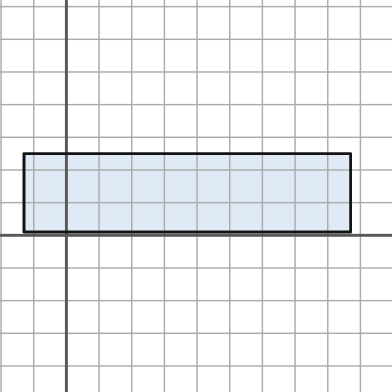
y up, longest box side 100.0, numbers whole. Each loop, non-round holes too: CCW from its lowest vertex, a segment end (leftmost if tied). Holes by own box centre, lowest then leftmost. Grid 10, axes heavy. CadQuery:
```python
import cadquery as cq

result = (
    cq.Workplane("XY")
    .moveTo(-13.0, 1.0)
    .lineTo(87.0, 1.0)
    .lineTo(87.0, 25.0)
    .lineTo(-13.0, 25.0)
    .close()
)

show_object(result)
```